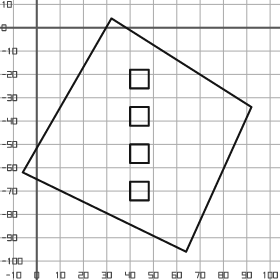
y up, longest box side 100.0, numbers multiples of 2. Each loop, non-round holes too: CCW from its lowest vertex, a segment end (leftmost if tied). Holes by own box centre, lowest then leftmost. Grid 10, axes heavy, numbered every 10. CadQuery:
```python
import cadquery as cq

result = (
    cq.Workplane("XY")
    .moveTo(64.0, -96.0)
    .lineTo(92.0, -34.0)
    .lineTo(32.0, 4.0)
    .lineTo(-6.0, -62.0)
    .close()
    .moveTo(40.0, -74.0)
    .lineTo(48.0, -74.0)
    .lineTo(48.0, -66.0)
    .lineTo(40.0, -66.0)
    .close()
    .moveTo(40.0, -58.0)
    .lineTo(48.0, -58.0)
    .lineTo(48.0, -50.0)
    .lineTo(40.0, -50.0)
    .close()
    .moveTo(40.0, -42.0)
    .lineTo(48.0, -42.0)
    .lineTo(48.0, -34.0)
    .lineTo(40.0, -34.0)
    .close()
    .moveTo(40.0, -26.0)
    .lineTo(48.0, -26.0)
    .lineTo(48.0, -18.0)
    .lineTo(40.0, -18.0)
    .close()
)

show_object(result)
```